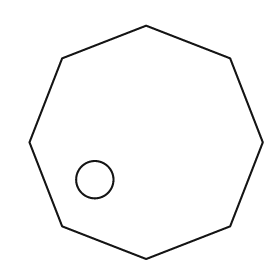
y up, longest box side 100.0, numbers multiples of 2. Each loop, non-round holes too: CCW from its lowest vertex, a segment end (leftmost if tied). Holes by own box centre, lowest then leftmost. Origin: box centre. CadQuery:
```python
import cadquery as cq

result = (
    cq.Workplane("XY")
    .moveTo(0.0, -50.0)
    .lineTo(36.0, -36.0)
    .lineTo(50.0, 0.0)
    .lineTo(36.0, 36.0)
    .lineTo(0.0, 50.0)
    .lineTo(-36.0, 36.0)
    .lineTo(-50.0, 0.0)
    .lineTo(-36.0, -36.0)
    .close()
    .moveTo(-22.0, -16.0)
    .circle(8.0)
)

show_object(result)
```